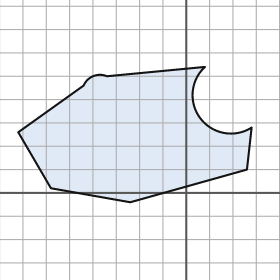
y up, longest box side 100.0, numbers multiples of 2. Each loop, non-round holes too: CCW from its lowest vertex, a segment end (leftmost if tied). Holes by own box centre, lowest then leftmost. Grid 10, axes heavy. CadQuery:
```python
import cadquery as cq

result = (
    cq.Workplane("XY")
    .moveTo(-24.0, -4.0)
    .lineTo(26.0, 10.0)
    .lineTo(28.0, 28.0)
    .threePointArc((6.0, 32.0), (8.0, 54.0))
    .lineTo(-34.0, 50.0)
    .threePointArc((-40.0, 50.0), (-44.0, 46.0))
    .lineTo(-72.0, 26.0)
    .lineTo(-58.0, 2.0)
    .close()
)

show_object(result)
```